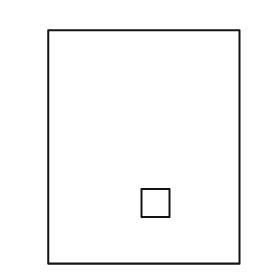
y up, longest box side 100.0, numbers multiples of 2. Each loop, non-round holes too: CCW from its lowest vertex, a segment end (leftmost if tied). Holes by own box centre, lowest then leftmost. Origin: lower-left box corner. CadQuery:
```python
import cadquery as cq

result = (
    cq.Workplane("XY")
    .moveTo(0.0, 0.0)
    .lineTo(82.0, 0.0)
    .lineTo(82.0, 100.0)
    .lineTo(0.0, 100.0)
    .close()
    .moveTo(40.0, 20.0)
    .lineTo(52.0, 20.0)
    .lineTo(52.0, 32.0)
    .lineTo(40.0, 32.0)
    .close()
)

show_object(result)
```